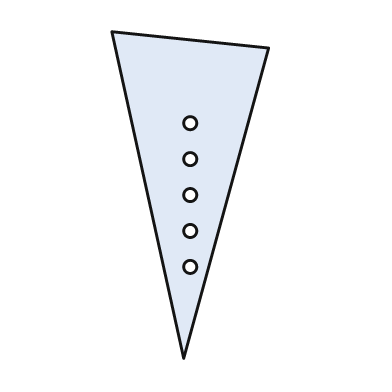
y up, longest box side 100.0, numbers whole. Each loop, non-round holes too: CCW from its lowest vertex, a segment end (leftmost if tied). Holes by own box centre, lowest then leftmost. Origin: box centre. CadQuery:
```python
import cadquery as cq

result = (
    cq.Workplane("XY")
    .moveTo(-2.0, -50.0)
    .lineTo(24.0, 45.0)
    .lineTo(-24.0, 50.0)
    .close()
    .moveTo(0.0, -22.0)
    .circle(2.0)
    .moveTo(0.0, -11.0)
    .circle(2.0)
    .moveTo(0.0, 0.0)
    .circle(2.0)
    .moveTo(0.0, 11.0)
    .circle(2.0)
    .moveTo(0.0, 22.0)
    .circle(2.0)
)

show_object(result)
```